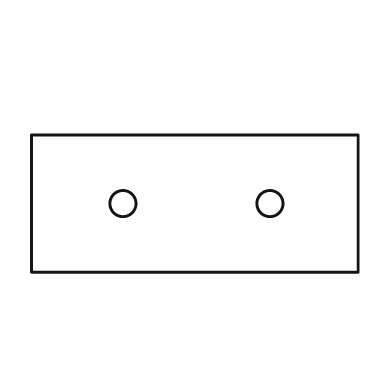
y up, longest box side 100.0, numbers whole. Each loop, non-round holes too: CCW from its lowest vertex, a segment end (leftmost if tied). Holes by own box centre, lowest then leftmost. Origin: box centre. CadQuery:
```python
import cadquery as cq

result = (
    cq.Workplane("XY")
    .moveTo(-50.0, -21.0)
    .lineTo(50.0, -21.0)
    .lineTo(50.0, 21.0)
    .lineTo(-50.0, 21.0)
    .close()
    .moveTo(-22.0, 0.0)
    .circle(4.0)
    .moveTo(23.0, 0.0)
    .circle(4.0)
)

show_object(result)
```